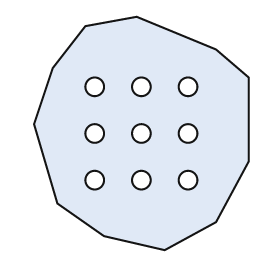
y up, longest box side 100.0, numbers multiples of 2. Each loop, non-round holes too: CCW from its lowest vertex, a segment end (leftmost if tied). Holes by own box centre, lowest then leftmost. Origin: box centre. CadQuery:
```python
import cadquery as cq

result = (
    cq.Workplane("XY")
    .moveTo(10.0, -50.0)
    .lineTo(32.0, -38.0)
    .lineTo(46.0, -12.0)
    .lineTo(46.0, 24.0)
    .lineTo(32.0, 36.0)
    .lineTo(-2.0, 50.0)
    .lineTo(-24.0, 46.0)
    .lineTo(-38.0, 28.0)
    .lineTo(-46.0, 4.0)
    .lineTo(-36.0, -30.0)
    .lineTo(-16.0, -44.0)
    .close()
    .moveTo(-20.0, -20.0)
    .circle(4.0)
    .moveTo(0.0, -20.0)
    .circle(4.0)
    .moveTo(20.0, -20.0)
    .circle(4.0)
    .moveTo(-20.0, 0.0)
    .circle(4.0)
    .moveTo(0.0, 0.0)
    .circle(4.0)
    .moveTo(20.0, 0.0)
    .circle(4.0)
    .moveTo(-20.0, 20.0)
    .circle(4.0)
    .moveTo(0.0, 20.0)
    .circle(4.0)
    .moveTo(20.0, 20.0)
    .circle(4.0)
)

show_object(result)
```